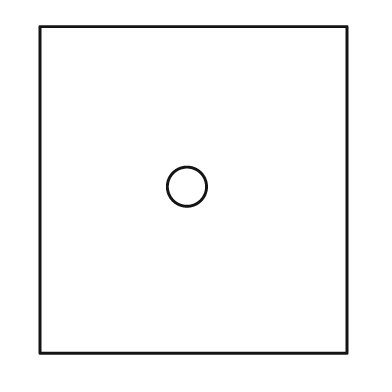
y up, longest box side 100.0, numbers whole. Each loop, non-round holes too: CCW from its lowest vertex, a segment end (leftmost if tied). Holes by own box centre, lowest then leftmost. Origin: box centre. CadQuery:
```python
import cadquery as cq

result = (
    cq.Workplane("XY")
    .moveTo(-47.0, -50.0)
    .lineTo(47.0, -50.0)
    .lineTo(47.0, 50.0)
    .lineTo(-47.0, 50.0)
    .close()
    .moveTo(-2.0, 1.0)
    .circle(6.0)
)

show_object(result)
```